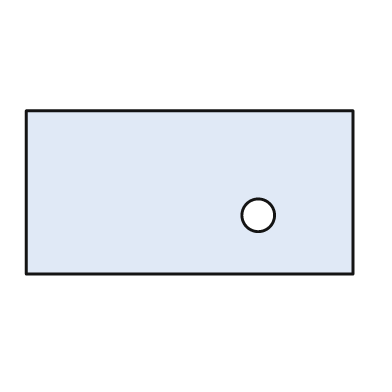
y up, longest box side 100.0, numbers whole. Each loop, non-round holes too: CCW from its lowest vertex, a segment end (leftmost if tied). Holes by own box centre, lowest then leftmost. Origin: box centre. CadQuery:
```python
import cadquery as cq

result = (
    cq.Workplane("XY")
    .moveTo(-50.0, -25.0)
    .lineTo(50.0, -25.0)
    .lineTo(50.0, 25.0)
    .lineTo(-50.0, 25.0)
    .close()
    .moveTo(21.0, -7.0)
    .circle(5.0)
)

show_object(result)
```